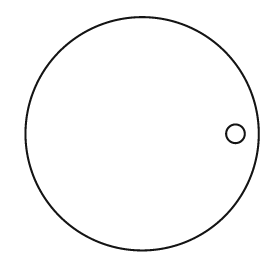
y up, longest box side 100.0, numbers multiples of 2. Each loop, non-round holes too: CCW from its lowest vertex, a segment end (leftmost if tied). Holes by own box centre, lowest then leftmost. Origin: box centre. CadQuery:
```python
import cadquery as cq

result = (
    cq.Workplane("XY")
    .moveTo(0.0, 0.0)
    .circle(50.0)
    .moveTo(40.0, 0.0)
    .circle(4.0)
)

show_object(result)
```